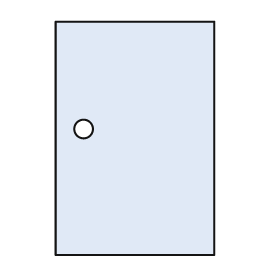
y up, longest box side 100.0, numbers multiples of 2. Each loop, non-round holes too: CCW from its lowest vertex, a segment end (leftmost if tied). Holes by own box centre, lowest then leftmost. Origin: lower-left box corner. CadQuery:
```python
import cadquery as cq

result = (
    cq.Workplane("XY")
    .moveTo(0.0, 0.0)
    .lineTo(68.0, 0.0)
    .lineTo(68.0, 100.0)
    .lineTo(0.0, 100.0)
    .close()
    .moveTo(12.0, 54.0)
    .circle(4.0)
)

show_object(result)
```